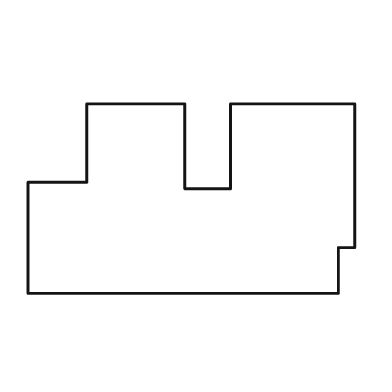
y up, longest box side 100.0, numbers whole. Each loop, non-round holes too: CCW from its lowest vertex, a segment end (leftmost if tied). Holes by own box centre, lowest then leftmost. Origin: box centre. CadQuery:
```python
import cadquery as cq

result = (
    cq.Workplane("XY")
    .moveTo(-50.0, -29.0)
    .lineTo(45.0, -29.0)
    .lineTo(45.0, -15.0)
    .lineTo(50.0, -15.0)
    .lineTo(50.0, 29.0)
    .lineTo(12.0, 29.0)
    .lineTo(12.0, 3.0)
    .lineTo(-2.0, 3.0)
    .lineTo(-2.0, 29.0)
    .lineTo(-32.0, 29.0)
    .lineTo(-32.0, 5.0)
    .lineTo(-50.0, 5.0)
    .close()
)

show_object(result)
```